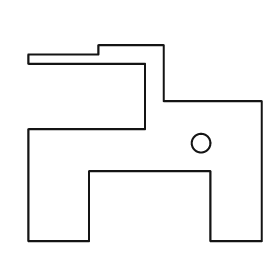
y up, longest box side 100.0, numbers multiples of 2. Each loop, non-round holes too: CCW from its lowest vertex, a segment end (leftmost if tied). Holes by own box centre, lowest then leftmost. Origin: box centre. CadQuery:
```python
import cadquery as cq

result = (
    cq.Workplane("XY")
    .moveTo(-50.0, -42.0)
    .lineTo(-24.0, -42.0)
    .lineTo(-24.0, -12.0)
    .lineTo(28.0, -12.0)
    .lineTo(28.0, -42.0)
    .lineTo(50.0, -42.0)
    .lineTo(50.0, 18.0)
    .lineTo(8.0, 18.0)
    .lineTo(8.0, 42.0)
    .lineTo(-20.0, 42.0)
    .lineTo(-20.0, 38.0)
    .lineTo(-50.0, 38.0)
    .lineTo(-50.0, 34.0)
    .lineTo(0.0, 34.0)
    .lineTo(0.0, 6.0)
    .lineTo(-50.0, 6.0)
    .close()
    .moveTo(24.0, 0.0)
    .circle(4.0)
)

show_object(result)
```